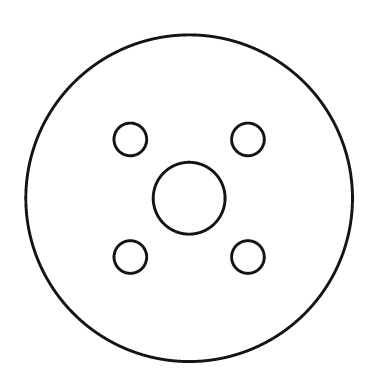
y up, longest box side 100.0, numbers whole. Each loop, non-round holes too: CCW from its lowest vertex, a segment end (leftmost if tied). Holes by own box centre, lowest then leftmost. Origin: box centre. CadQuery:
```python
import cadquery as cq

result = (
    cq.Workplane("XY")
    .moveTo(0.0, 0.0)
    .circle(50.0)
    .moveTo(-18.0, -18.0)
    .circle(5.0)
    .moveTo(18.0, -18.0)
    .circle(5.0)
    .moveTo(0.0, 0.0)
    .circle(11.0)
    .moveTo(-18.0, 18.0)
    .circle(5.0)
    .moveTo(18.0, 18.0)
    .circle(5.0)
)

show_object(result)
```